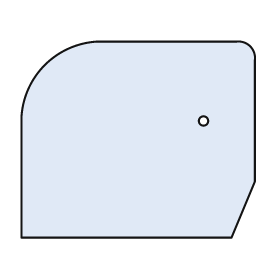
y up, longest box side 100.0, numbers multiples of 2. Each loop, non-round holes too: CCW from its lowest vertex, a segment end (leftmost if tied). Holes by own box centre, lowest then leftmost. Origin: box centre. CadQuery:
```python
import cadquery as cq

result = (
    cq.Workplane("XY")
    .moveTo(-50.0, -42.0)
    .lineTo(40.0, -42.0)
    .lineTo(50.0, -18.0)
    .lineTo(50.0, 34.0)
    .threePointArc((48.0, 40.0), (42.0, 42.0))
    .lineTo(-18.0, 42.0)
    .threePointArc((-40.0, 32.0), (-50.0, 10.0))
    .close()
    .moveTo(28.0, 8.0)
    .circle(2.0)
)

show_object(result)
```